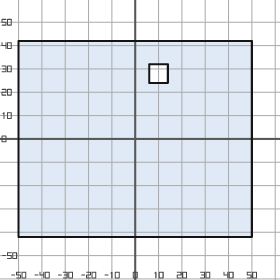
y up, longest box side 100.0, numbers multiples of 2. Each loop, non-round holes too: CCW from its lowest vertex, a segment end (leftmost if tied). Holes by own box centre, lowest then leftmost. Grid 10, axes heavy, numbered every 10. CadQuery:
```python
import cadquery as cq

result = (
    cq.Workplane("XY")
    .moveTo(-50.0, -42.0)
    .lineTo(50.0, -42.0)
    .lineTo(50.0, 42.0)
    .lineTo(-50.0, 42.0)
    .close()
    .moveTo(6.0, 24.0)
    .lineTo(14.0, 24.0)
    .lineTo(14.0, 32.0)
    .lineTo(6.0, 32.0)
    .close()
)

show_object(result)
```